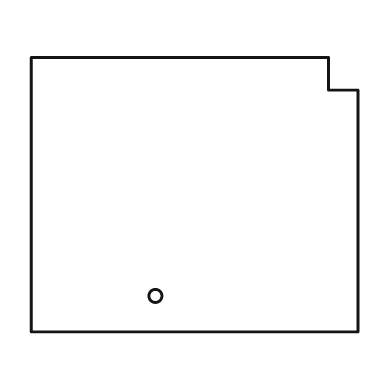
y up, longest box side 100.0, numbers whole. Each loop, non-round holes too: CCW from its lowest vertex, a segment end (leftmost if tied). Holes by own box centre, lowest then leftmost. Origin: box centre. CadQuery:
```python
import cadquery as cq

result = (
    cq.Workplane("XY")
    .moveTo(-50.0, -42.0)
    .lineTo(50.0, -42.0)
    .lineTo(50.0, 32.0)
    .lineTo(41.0, 32.0)
    .lineTo(41.0, 42.0)
    .lineTo(-50.0, 42.0)
    .close()
    .moveTo(-12.0, -31.0)
    .circle(2.0)
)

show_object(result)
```